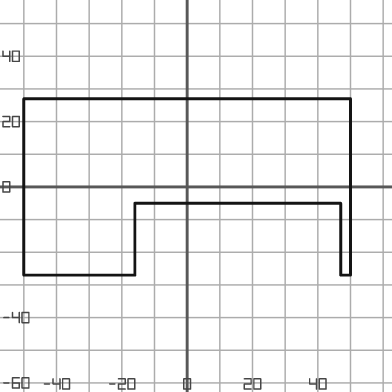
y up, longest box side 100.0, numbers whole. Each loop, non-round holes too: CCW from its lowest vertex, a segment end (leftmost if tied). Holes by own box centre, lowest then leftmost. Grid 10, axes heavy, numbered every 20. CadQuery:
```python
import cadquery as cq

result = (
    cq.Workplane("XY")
    .moveTo(-50.0, -27.0)
    .lineTo(-16.0, -27.0)
    .lineTo(-16.0, -5.0)
    .lineTo(47.0, -5.0)
    .lineTo(47.0, -27.0)
    .lineTo(50.0, -27.0)
    .lineTo(50.0, 27.0)
    .lineTo(-50.0, 27.0)
    .close()
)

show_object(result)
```